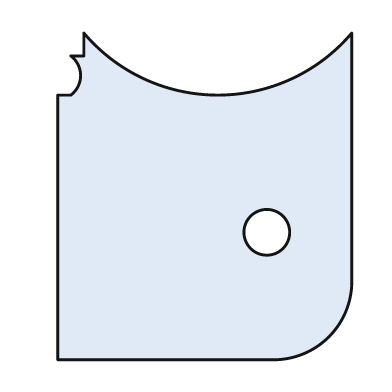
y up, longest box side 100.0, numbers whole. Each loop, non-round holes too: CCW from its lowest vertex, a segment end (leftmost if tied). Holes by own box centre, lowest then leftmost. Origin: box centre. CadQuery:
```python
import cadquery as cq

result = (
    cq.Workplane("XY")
    .moveTo(-45.0, -50.0)
    .lineTo(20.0, -50.0)
    .threePointArc((38.0, -43.0), (45.0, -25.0))
    .lineTo(45.0, 50.0)
    .threePointArc((4.0, 31.0), (-37.0, 50.0))
    .lineTo(-37.0, 43.0)
    .lineTo(-41.0, 43.0)
    .threePointArc((-38.0, 37.0), (-41.0, 31.0))
    .lineTo(-45.0, 31.0)
    .close()
    .moveTo(19.0, -11.0)
    .circle(7.0)
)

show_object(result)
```